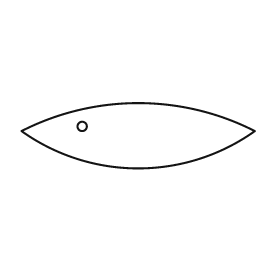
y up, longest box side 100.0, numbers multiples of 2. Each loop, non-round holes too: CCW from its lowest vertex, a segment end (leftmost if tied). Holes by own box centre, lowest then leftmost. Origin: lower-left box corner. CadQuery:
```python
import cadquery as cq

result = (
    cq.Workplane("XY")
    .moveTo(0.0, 16.0)
    .threePointArc((50.0, 0.0), (100.0, 16.0))
    .threePointArc((50.0, 28.0), (0.0, 16.0))
    .close()
    .moveTo(26.0, 18.0)
    .circle(2.0)
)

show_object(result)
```